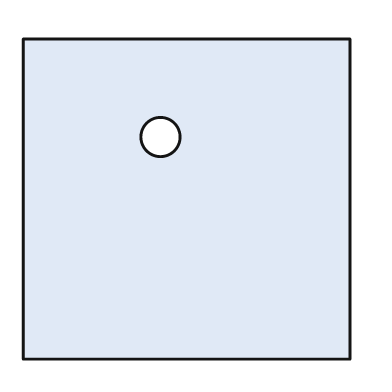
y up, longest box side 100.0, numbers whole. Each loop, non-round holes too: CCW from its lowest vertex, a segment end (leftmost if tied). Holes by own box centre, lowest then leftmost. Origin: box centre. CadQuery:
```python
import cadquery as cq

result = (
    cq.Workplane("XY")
    .moveTo(-50.0, -49.0)
    .lineTo(50.0, -49.0)
    .lineTo(50.0, 49.0)
    .lineTo(-50.0, 49.0)
    .close()
    .moveTo(-8.0, 19.0)
    .circle(6.0)
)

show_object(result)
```